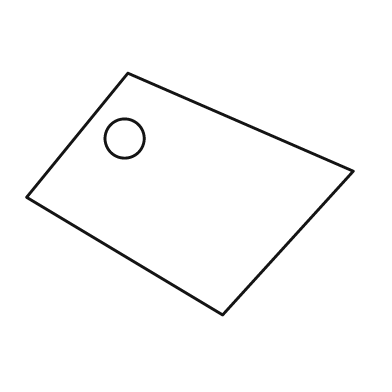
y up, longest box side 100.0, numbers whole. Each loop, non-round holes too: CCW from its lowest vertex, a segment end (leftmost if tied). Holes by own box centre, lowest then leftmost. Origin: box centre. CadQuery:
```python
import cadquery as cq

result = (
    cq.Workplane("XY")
    .moveTo(10.0, -37.0)
    .lineTo(50.0, 7.0)
    .lineTo(-19.0, 37.0)
    .lineTo(-50.0, -1.0)
    .close()
    .moveTo(-20.0, 17.0)
    .circle(6.0)
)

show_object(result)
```